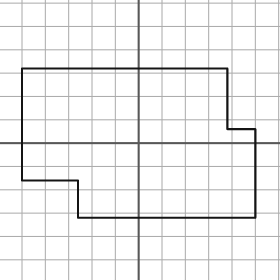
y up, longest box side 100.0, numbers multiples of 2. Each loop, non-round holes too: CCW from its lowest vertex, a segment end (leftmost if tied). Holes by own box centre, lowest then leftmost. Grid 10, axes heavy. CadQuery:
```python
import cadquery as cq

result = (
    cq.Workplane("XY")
    .moveTo(-26.0, -32.0)
    .lineTo(50.0, -32.0)
    .lineTo(50.0, 6.0)
    .lineTo(38.0, 6.0)
    .lineTo(38.0, 32.0)
    .lineTo(-50.0, 32.0)
    .lineTo(-50.0, -16.0)
    .lineTo(-26.0, -16.0)
    .close()
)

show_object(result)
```